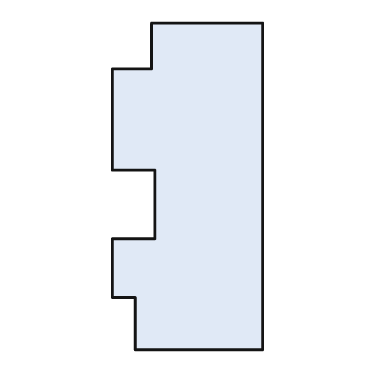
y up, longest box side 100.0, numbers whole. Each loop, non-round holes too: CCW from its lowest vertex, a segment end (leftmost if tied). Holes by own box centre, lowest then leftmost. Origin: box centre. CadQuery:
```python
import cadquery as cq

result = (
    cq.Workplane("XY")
    .moveTo(-16.0, -50.0)
    .lineTo(23.0, -50.0)
    .lineTo(23.0, 50.0)
    .lineTo(-11.0, 50.0)
    .lineTo(-11.0, 36.0)
    .lineTo(-23.0, 36.0)
    .lineTo(-23.0, 5.0)
    .lineTo(-10.0, 5.0)
    .lineTo(-10.0, -16.0)
    .lineTo(-23.0, -16.0)
    .lineTo(-23.0, -34.0)
    .lineTo(-16.0, -34.0)
    .close()
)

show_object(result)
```